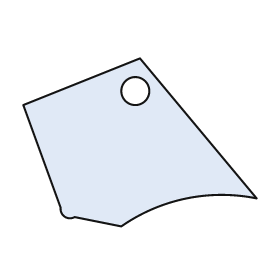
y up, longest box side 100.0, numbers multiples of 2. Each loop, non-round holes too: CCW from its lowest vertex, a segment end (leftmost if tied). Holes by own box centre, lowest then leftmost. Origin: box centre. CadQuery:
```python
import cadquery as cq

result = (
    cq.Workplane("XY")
    .moveTo(-8.0, -36.0)
    .threePointArc((20.0, -24.0), (50.0, -24.0))
    .lineTo(0.0, 36.0)
    .lineTo(-50.0, 16.0)
    .lineTo(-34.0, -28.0)
    .threePointArc((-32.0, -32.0), (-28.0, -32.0))
    .close()
    .moveTo(-2.0, 22.0)
    .circle(6.0)
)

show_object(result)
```